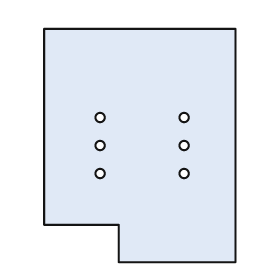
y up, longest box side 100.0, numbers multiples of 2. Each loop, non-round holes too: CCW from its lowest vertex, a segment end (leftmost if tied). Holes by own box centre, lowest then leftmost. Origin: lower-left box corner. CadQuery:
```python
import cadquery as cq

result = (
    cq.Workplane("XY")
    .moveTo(32.0, 0.0)
    .lineTo(82.0, 0.0)
    .lineTo(82.0, 100.0)
    .lineTo(0.0, 100.0)
    .lineTo(0.0, 16.0)
    .lineTo(32.0, 16.0)
    .close()
    .moveTo(24.0, 38.0)
    .circle(2.0)
    .moveTo(60.0, 38.0)
    .circle(2.0)
    .moveTo(24.0, 50.0)
    .circle(2.0)
    .moveTo(60.0, 50.0)
    .circle(2.0)
    .moveTo(24.0, 62.0)
    .circle(2.0)
    .moveTo(60.0, 62.0)
    .circle(2.0)
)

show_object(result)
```